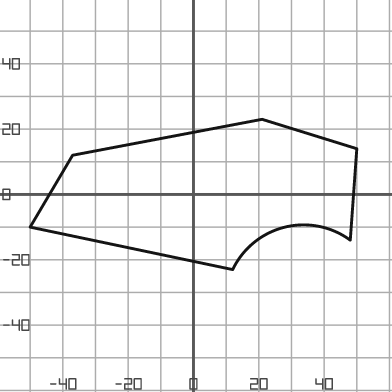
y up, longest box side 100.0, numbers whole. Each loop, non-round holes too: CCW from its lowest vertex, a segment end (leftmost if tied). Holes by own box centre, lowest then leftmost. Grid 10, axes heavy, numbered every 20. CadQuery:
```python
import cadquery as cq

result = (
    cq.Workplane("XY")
    .moveTo(12.0, -23.0)
    .threePointArc((28.0, -10.0), (48.0, -14.0))
    .lineTo(50.0, 14.0)
    .lineTo(21.0, 23.0)
    .lineTo(-37.0, 12.0)
    .lineTo(-50.0, -10.0)
    .close()
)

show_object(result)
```